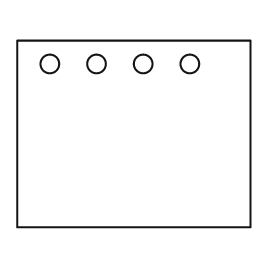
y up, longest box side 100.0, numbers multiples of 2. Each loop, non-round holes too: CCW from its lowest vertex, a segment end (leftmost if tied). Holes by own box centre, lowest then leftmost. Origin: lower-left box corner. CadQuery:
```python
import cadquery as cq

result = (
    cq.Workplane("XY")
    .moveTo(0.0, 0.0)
    .lineTo(100.0, 0.0)
    .lineTo(100.0, 80.0)
    .lineTo(0.0, 80.0)
    .close()
    .moveTo(14.0, 70.0)
    .circle(4.0)
    .moveTo(34.0, 70.0)
    .circle(4.0)
    .moveTo(54.0, 70.0)
    .circle(4.0)
    .moveTo(74.0, 70.0)
    .circle(4.0)
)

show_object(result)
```